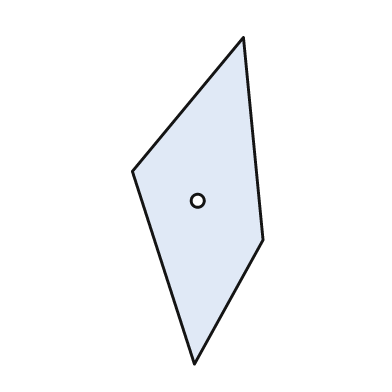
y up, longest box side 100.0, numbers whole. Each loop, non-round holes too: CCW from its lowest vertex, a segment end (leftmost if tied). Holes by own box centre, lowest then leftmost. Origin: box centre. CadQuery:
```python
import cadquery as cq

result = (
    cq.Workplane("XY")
    .moveTo(-1.0, -50.0)
    .lineTo(20.0, -12.0)
    .lineTo(14.0, 50.0)
    .lineTo(-20.0, 9.0)
    .close()
    .moveTo(0.0, 0.0)
    .circle(2.0)
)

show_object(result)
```